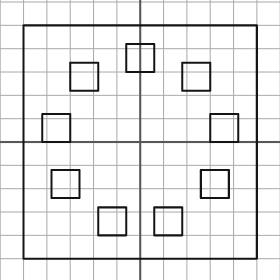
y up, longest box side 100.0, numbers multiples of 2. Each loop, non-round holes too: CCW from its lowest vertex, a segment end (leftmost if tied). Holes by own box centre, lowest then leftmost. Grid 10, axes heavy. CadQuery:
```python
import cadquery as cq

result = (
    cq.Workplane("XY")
    .moveTo(-50.0, -50.0)
    .lineTo(50.0, -50.0)
    .lineTo(50.0, 50.0)
    .lineTo(-50.0, 50.0)
    .close()
    .moveTo(-18.0, -40.0)
    .lineTo(-6.0, -40.0)
    .lineTo(-6.0, -28.0)
    .lineTo(-18.0, -28.0)
    .close()
    .moveTo(6.0, -40.0)
    .lineTo(18.0, -40.0)
    .lineTo(18.0, -28.0)
    .lineTo(6.0, -28.0)
    .close()
    .moveTo(-38.0, -24.0)
    .lineTo(-26.0, -24.0)
    .lineTo(-26.0, -12.0)
    .lineTo(-38.0, -12.0)
    .close()
    .moveTo(26.0, -24.0)
    .lineTo(38.0, -24.0)
    .lineTo(38.0, -12.0)
    .lineTo(26.0, -12.0)
    .close()
    .moveTo(-42.0, 0.0)
    .lineTo(-30.0, 0.0)
    .lineTo(-30.0, 12.0)
    .lineTo(-42.0, 12.0)
    .close()
    .moveTo(30.0, 0.0)
    .lineTo(42.0, 0.0)
    .lineTo(42.0, 12.0)
    .lineTo(30.0, 12.0)
    .close()
    .moveTo(-30.0, 22.0)
    .lineTo(-18.0, 22.0)
    .lineTo(-18.0, 34.0)
    .lineTo(-30.0, 34.0)
    .close()
    .moveTo(18.0, 22.0)
    .lineTo(30.0, 22.0)
    .lineTo(30.0, 34.0)
    .lineTo(18.0, 34.0)
    .close()
    .moveTo(-6.0, 30.0)
    .lineTo(6.0, 30.0)
    .lineTo(6.0, 42.0)
    .lineTo(-6.0, 42.0)
    .close()
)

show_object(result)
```